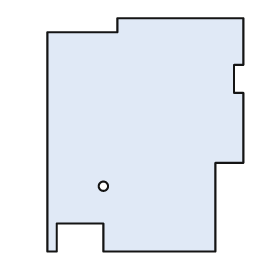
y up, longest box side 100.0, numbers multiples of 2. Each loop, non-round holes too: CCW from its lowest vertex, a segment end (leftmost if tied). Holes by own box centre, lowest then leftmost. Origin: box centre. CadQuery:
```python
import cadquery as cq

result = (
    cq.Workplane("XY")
    .moveTo(-42.0, -50.0)
    .lineTo(-38.0, -50.0)
    .lineTo(-38.0, -38.0)
    .lineTo(-18.0, -38.0)
    .lineTo(-18.0, -50.0)
    .lineTo(30.0, -50.0)
    .lineTo(30.0, -12.0)
    .lineTo(42.0, -12.0)
    .lineTo(42.0, 18.0)
    .lineTo(38.0, 18.0)
    .lineTo(38.0, 30.0)
    .lineTo(42.0, 30.0)
    .lineTo(42.0, 50.0)
    .lineTo(-12.0, 50.0)
    .lineTo(-12.0, 44.0)
    .lineTo(-42.0, 44.0)
    .close()
    .moveTo(-18.0, -22.0)
    .circle(2.0)
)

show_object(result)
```